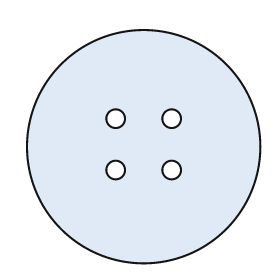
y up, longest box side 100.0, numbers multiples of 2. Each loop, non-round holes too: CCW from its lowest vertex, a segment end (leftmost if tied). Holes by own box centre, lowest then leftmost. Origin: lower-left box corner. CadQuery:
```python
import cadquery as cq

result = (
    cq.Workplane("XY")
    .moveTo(50.0, 50.0)
    .circle(50.0)
    .moveTo(38.0, 40.0)
    .circle(4.0)
    .moveTo(62.0, 40.0)
    .circle(4.0)
    .moveTo(38.0, 62.0)
    .circle(4.0)
    .moveTo(62.0, 62.0)
    .circle(4.0)
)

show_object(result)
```